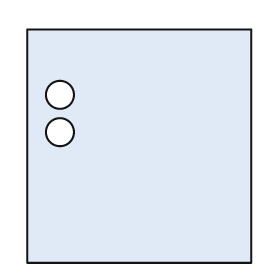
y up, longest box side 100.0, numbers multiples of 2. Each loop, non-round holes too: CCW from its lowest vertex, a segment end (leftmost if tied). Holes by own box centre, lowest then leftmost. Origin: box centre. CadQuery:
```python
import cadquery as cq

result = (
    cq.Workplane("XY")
    .moveTo(-48.0, -50.0)
    .lineTo(48.0, -50.0)
    .lineTo(48.0, 50.0)
    .lineTo(-48.0, 50.0)
    .close()
    .moveTo(-34.0, 6.0)
    .circle(6.0)
    .moveTo(-34.0, 22.0)
    .circle(6.0)
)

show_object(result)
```